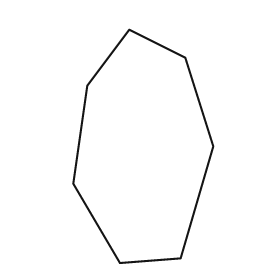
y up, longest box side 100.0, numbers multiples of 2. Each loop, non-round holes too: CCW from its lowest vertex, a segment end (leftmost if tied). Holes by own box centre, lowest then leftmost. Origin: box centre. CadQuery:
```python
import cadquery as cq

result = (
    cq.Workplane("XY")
    .moveTo(-10.0, -50.0)
    .lineTo(16.0, -48.0)
    .lineTo(30.0, 0.0)
    .lineTo(18.0, 38.0)
    .lineTo(-6.0, 50.0)
    .lineTo(-24.0, 26.0)
    .lineTo(-30.0, -16.0)
    .close()
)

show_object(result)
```